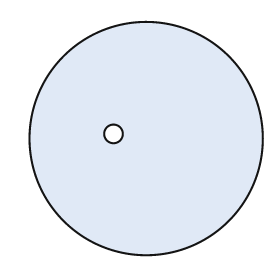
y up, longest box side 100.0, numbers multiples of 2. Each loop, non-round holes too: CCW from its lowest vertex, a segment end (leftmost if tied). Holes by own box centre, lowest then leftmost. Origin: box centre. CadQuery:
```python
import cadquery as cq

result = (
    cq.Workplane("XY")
    .moveTo(0.0, 0.0)
    .circle(50.0)
    .moveTo(-14.0, 2.0)
    .circle(4.0)
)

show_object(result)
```